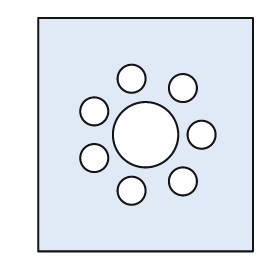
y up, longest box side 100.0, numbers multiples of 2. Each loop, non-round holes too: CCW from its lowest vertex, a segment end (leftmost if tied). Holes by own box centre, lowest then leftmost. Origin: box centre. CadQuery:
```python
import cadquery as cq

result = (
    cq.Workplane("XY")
    .moveTo(-46.0, -50.0)
    .lineTo(46.0, -50.0)
    .lineTo(46.0, 50.0)
    .lineTo(-46.0, 50.0)
    .close()
    .moveTo(-6.0, -24.0)
    .circle(6.0)
    .moveTo(16.0, -20.0)
    .circle(6.0)
    .moveTo(-22.0, -10.0)
    .circle(6.0)
    .moveTo(0.0, 0.0)
    .circle(14.0)
    .moveTo(24.0, 0.0)
    .circle(6.0)
    .moveTo(-22.0, 10.0)
    .circle(6.0)
    .moveTo(16.0, 20.0)
    .circle(6.0)
    .moveTo(-6.0, 24.0)
    .circle(6.0)
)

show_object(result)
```